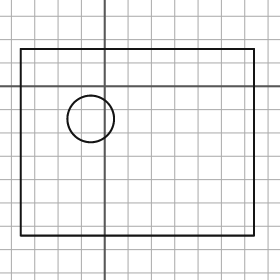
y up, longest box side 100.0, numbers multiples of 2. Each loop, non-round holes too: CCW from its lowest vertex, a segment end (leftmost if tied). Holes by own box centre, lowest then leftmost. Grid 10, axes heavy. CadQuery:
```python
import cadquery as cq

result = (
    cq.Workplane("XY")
    .moveTo(-36.0, -64.0)
    .lineTo(64.0, -64.0)
    .lineTo(64.0, 16.0)
    .lineTo(-36.0, 16.0)
    .close()
    .moveTo(-6.0, -14.0)
    .circle(10.0)
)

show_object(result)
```